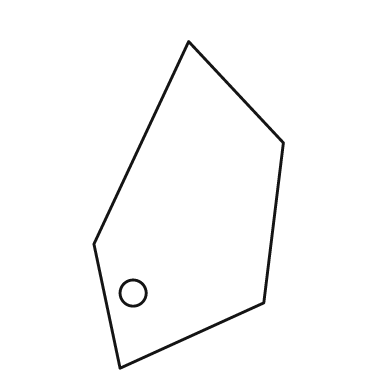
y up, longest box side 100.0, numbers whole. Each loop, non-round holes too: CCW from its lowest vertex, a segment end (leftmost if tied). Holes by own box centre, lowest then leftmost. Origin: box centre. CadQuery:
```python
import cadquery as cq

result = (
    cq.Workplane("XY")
    .moveTo(-21.0, -50.0)
    .lineTo(23.0, -30.0)
    .lineTo(29.0, 19.0)
    .lineTo(0.0, 50.0)
    .lineTo(-29.0, -12.0)
    .close()
    .moveTo(-17.0, -27.0)
    .circle(4.0)
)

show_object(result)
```